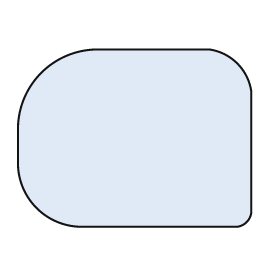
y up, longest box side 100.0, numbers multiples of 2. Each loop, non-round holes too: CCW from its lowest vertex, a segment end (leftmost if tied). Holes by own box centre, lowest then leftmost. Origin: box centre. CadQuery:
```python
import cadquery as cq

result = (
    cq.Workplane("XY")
    .moveTo(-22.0, -38.0)
    .lineTo(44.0, -38.0)
    .threePointArc((48.0, -36.0), (50.0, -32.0))
    .lineTo(50.0, 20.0)
    .threePointArc((44.0, 32.0), (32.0, 38.0))
    .lineTo(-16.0, 38.0)
    .threePointArc((-40.0, 28.0), (-50.0, 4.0))
    .lineTo(-50.0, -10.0)
    .threePointArc((-42.0, -30.0), (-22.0, -38.0))
    .close()
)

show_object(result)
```